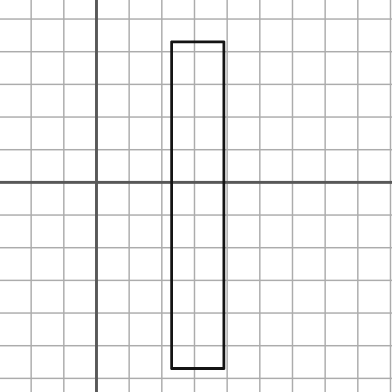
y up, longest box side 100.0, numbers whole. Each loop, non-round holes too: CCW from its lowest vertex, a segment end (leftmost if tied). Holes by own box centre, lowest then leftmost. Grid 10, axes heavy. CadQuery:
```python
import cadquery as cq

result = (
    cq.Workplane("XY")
    .moveTo(23.0, -57.0)
    .lineTo(39.0, -57.0)
    .lineTo(39.0, 43.0)
    .lineTo(23.0, 43.0)
    .close()
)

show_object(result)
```